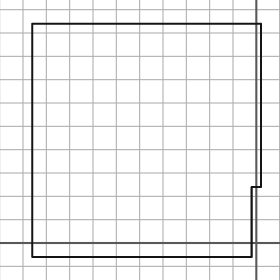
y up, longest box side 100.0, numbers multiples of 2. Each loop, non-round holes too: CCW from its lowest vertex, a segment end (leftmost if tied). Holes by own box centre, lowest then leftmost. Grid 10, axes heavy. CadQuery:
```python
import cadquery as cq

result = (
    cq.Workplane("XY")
    .moveTo(-96.0, -6.0)
    .lineTo(-2.0, -6.0)
    .lineTo(-2.0, 24.0)
    .lineTo(2.0, 24.0)
    .lineTo(2.0, 94.0)
    .lineTo(-96.0, 94.0)
    .close()
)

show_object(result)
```